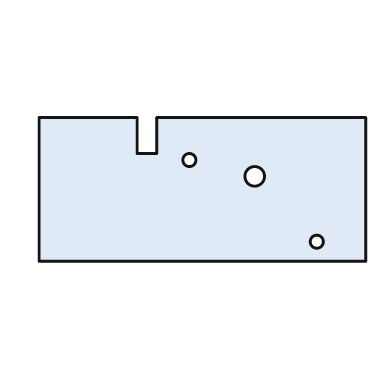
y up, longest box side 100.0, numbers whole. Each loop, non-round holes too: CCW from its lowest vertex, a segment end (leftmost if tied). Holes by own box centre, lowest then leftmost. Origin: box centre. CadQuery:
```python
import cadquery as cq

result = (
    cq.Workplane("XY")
    .moveTo(-50.0, -22.0)
    .lineTo(50.0, -22.0)
    .lineTo(50.0, 22.0)
    .lineTo(-14.0, 22.0)
    .lineTo(-14.0, 11.0)
    .lineTo(-20.0, 11.0)
    .lineTo(-20.0, 22.0)
    .lineTo(-50.0, 22.0)
    .close()
    .moveTo(35.0, -16.0)
    .circle(2.0)
    .moveTo(16.0, 4.0)
    .circle(3.0)
    .moveTo(-4.0, 9.0)
    .circle(2.0)
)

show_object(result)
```